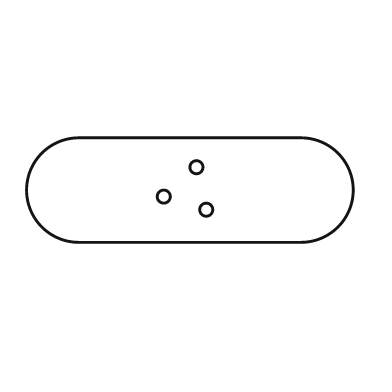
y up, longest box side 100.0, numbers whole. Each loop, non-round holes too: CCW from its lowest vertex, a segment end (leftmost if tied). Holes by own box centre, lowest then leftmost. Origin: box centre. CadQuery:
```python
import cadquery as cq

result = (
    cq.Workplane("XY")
    .moveTo(-34.0, -16.0)
    .lineTo(34.0, -16.0)
    .threePointArc((50.0, 0.0), (34.0, 16.0))
    .lineTo(-34.0, 16.0)
    .threePointArc((-50.0, 0.0), (-34.0, -16.0))
    .close()
    .moveTo(5.0, -6.0)
    .circle(2.0)
    .moveTo(-8.0, -2.0)
    .circle(2.0)
    .moveTo(2.0, 7.0)
    .circle(2.0)
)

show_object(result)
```